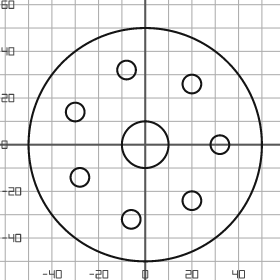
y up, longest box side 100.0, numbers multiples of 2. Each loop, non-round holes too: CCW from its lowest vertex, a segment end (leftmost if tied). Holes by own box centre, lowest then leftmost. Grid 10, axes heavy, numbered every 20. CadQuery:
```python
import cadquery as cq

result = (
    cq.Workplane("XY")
    .moveTo(0.0, 0.0)
    .circle(50.0)
    .moveTo(-6.0, -32.0)
    .circle(4.0)
    .moveTo(20.0, -24.0)
    .circle(4.0)
    .moveTo(-28.0, -14.0)
    .circle(4.0)
    .moveTo(0.0, 0.0)
    .circle(10.0)
    .moveTo(32.0, 0.0)
    .circle(4.0)
    .moveTo(-30.0, 14.0)
    .circle(4.0)
    .moveTo(20.0, 26.0)
    .circle(4.0)
    .moveTo(-8.0, 32.0)
    .circle(4.0)
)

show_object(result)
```